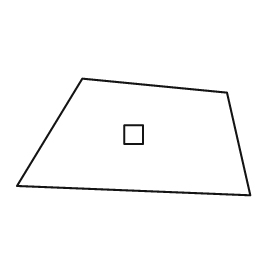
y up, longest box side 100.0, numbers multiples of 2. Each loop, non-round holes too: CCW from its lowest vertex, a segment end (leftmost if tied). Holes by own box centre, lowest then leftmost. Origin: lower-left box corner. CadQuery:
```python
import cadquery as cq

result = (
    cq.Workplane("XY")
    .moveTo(100.0, 0.0)
    .lineTo(90.0, 44.0)
    .lineTo(28.0, 50.0)
    .lineTo(0.0, 4.0)
    .close()
    .moveTo(46.0, 22.0)
    .lineTo(54.0, 22.0)
    .lineTo(54.0, 30.0)
    .lineTo(46.0, 30.0)
    .close()
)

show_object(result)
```